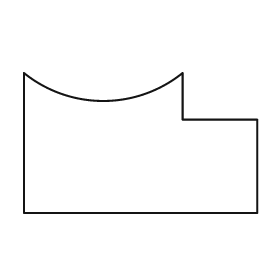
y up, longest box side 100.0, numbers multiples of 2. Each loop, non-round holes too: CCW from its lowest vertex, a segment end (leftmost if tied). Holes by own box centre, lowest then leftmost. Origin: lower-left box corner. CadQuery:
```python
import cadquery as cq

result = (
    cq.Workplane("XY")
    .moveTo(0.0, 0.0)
    .lineTo(100.0, 0.0)
    .lineTo(100.0, 40.0)
    .lineTo(68.0, 40.0)
    .lineTo(68.0, 60.0)
    .threePointArc((34.0, 48.0), (0.0, 60.0))
    .close()
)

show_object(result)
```